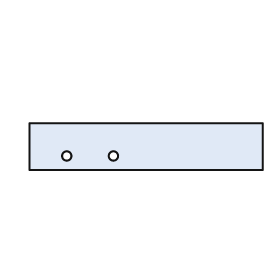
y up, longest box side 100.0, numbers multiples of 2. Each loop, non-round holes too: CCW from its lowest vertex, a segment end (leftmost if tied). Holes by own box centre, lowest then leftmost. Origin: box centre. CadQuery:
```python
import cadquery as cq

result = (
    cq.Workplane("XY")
    .moveTo(-50.0, -10.0)
    .lineTo(50.0, -10.0)
    .lineTo(50.0, 10.0)
    .lineTo(-50.0, 10.0)
    .close()
    .moveTo(-34.0, -4.0)
    .circle(2.0)
    .moveTo(-14.0, -4.0)
    .circle(2.0)
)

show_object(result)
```